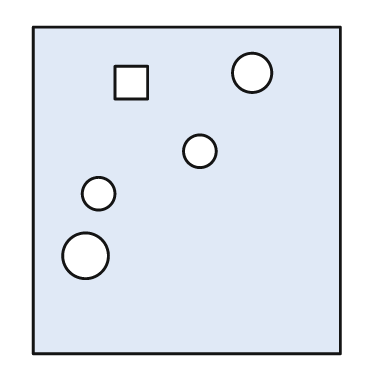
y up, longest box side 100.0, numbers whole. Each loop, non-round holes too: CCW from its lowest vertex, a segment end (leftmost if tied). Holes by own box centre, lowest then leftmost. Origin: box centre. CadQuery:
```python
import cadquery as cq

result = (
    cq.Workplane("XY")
    .moveTo(-47.0, -50.0)
    .lineTo(47.0, -50.0)
    .lineTo(47.0, 50.0)
    .lineTo(-47.0, 50.0)
    .close()
    .moveTo(-31.0, -20.0)
    .circle(7.0)
    .moveTo(-27.0, -1.0)
    .circle(5.0)
    .moveTo(4.0, 12.0)
    .circle(5.0)
    .moveTo(-22.0, 28.0)
    .lineTo(-12.0, 28.0)
    .lineTo(-12.0, 38.0)
    .lineTo(-22.0, 38.0)
    .close()
    .moveTo(20.0, 36.0)
    .circle(6.0)
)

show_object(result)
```